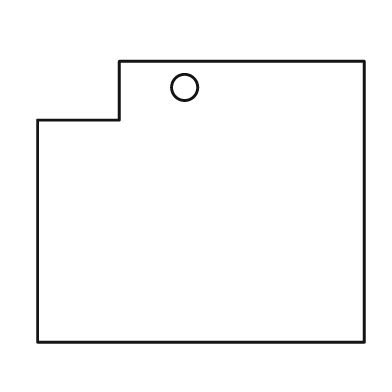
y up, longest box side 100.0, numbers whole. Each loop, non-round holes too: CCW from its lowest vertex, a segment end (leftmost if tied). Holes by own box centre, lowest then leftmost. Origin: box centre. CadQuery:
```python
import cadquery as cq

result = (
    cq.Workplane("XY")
    .moveTo(-50.0, -43.0)
    .lineTo(50.0, -43.0)
    .lineTo(50.0, 43.0)
    .lineTo(-25.0, 43.0)
    .lineTo(-25.0, 25.0)
    .lineTo(-50.0, 25.0)
    .close()
    .moveTo(-5.0, 35.0)
    .circle(4.0)
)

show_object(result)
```